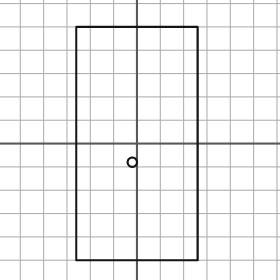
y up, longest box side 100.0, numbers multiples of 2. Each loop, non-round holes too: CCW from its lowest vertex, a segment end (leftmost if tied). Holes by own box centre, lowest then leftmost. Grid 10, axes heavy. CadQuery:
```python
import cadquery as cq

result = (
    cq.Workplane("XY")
    .moveTo(-26.0, -50.0)
    .lineTo(26.0, -50.0)
    .lineTo(26.0, 50.0)
    .lineTo(-26.0, 50.0)
    .close()
    .moveTo(-2.0, -8.0)
    .circle(2.0)
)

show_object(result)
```